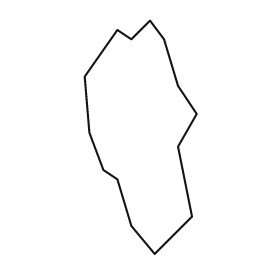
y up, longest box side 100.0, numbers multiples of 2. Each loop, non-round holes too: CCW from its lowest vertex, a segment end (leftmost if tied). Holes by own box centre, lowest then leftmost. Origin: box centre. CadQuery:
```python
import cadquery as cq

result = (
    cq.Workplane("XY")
    .moveTo(6.0, -50.0)
    .lineTo(22.0, -34.0)
    .lineTo(16.0, -4.0)
    .lineTo(24.0, 10.0)
    .lineTo(16.0, 22.0)
    .lineTo(10.0, 42.0)
    .lineTo(4.0, 50.0)
    .lineTo(-4.0, 42.0)
    .lineTo(-10.0, 46.0)
    .lineTo(-24.0, 26.0)
    .lineTo(-22.0, 2.0)
    .lineTo(-16.0, -14.0)
    .lineTo(-10.0, -18.0)
    .lineTo(-4.0, -38.0)
    .close()
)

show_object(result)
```